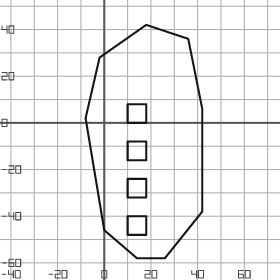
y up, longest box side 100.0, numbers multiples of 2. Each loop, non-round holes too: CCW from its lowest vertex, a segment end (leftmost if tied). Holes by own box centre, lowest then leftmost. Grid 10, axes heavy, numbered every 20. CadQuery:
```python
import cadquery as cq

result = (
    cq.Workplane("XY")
    .moveTo(14.0, -58.0)
    .lineTo(26.0, -58.0)
    .lineTo(42.0, -38.0)
    .lineTo(42.0, 6.0)
    .lineTo(36.0, 36.0)
    .lineTo(18.0, 42.0)
    .lineTo(-2.0, 28.0)
    .lineTo(-8.0, 2.0)
    .lineTo(0.0, -46.0)
    .close()
    .moveTo(10.0, -48.0)
    .lineTo(18.0, -48.0)
    .lineTo(18.0, -40.0)
    .lineTo(10.0, -40.0)
    .close()
    .moveTo(10.0, -32.0)
    .lineTo(18.0, -32.0)
    .lineTo(18.0, -24.0)
    .lineTo(10.0, -24.0)
    .close()
    .moveTo(10.0, -16.0)
    .lineTo(18.0, -16.0)
    .lineTo(18.0, -8.0)
    .lineTo(10.0, -8.0)
    .close()
    .moveTo(10.0, 0.0)
    .lineTo(18.0, 0.0)
    .lineTo(18.0, 8.0)
    .lineTo(10.0, 8.0)
    .close()
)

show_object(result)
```